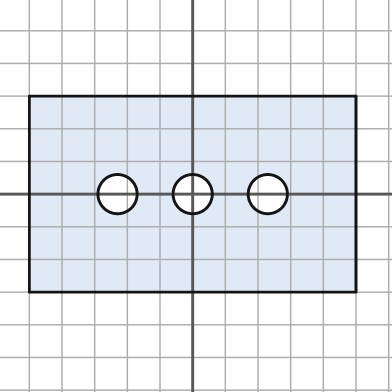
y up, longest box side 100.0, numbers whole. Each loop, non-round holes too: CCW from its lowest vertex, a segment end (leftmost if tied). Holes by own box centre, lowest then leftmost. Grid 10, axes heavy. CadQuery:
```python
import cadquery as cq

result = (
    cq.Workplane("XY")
    .moveTo(-50.0, -30.0)
    .lineTo(50.0, -30.0)
    .lineTo(50.0, 30.0)
    .lineTo(-50.0, 30.0)
    .close()
    .moveTo(-23.0, 0.0)
    .circle(6.0)
    .moveTo(0.0, 0.0)
    .circle(6.0)
    .moveTo(23.0, 0.0)
    .circle(6.0)
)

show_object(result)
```